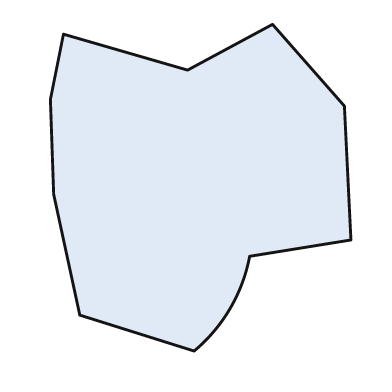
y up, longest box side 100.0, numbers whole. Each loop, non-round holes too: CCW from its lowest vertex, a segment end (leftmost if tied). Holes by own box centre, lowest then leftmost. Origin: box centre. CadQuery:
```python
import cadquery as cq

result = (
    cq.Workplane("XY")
    .moveTo(-2.0, -50.0)
    .threePointArc((9.0, -37.0), (15.0, -21.0))
    .lineTo(46.0, -16.0)
    .lineTo(44.0, 25.0)
    .lineTo(22.0, 50.0)
    .lineTo(-4.0, 36.0)
    .lineTo(-42.0, 47.0)
    .lineTo(-46.0, 27.0)
    .lineTo(-45.0, -2.0)
    .lineTo(-37.0, -39.0)
    .close()
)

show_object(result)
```